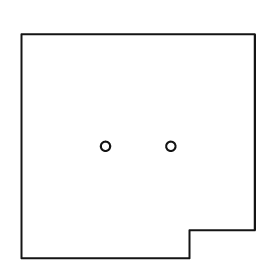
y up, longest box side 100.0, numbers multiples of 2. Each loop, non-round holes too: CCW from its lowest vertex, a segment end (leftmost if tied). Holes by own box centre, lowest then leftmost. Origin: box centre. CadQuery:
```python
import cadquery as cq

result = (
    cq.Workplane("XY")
    .moveTo(-50.0, -48.0)
    .lineTo(22.0, -48.0)
    .lineTo(22.0, -36.0)
    .lineTo(50.0, -36.0)
    .lineTo(50.0, 48.0)
    .lineTo(-50.0, 48.0)
    .close()
    .moveTo(-14.0, 0.0)
    .circle(2.0)
    .moveTo(14.0, 0.0)
    .circle(2.0)
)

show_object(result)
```